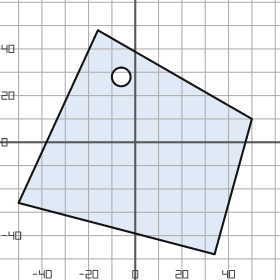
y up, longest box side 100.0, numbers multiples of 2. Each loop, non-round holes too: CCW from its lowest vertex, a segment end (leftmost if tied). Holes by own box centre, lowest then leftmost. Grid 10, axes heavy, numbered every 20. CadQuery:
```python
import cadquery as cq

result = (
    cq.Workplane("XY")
    .moveTo(34.0, -48.0)
    .lineTo(50.0, 10.0)
    .lineTo(-16.0, 48.0)
    .lineTo(-50.0, -26.0)
    .close()
    .moveTo(-6.0, 28.0)
    .circle(4.0)
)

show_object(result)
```